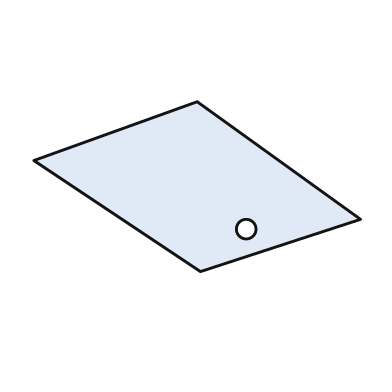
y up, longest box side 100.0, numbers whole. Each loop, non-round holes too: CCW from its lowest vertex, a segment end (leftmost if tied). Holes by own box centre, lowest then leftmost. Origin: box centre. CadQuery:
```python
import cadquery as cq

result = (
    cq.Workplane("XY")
    .moveTo(1.0, -26.0)
    .lineTo(50.0, -10.0)
    .lineTo(0.0, 26.0)
    .lineTo(-50.0, 8.0)
    .close()
    .moveTo(15.0, -13.0)
    .circle(3.0)
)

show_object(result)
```